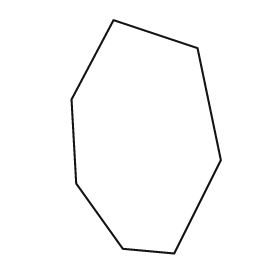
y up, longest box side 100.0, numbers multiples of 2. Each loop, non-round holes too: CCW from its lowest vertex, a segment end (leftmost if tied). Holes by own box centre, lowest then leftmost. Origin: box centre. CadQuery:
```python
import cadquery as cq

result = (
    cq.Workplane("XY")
    .moveTo(12.0, -50.0)
    .lineTo(32.0, -10.0)
    .lineTo(22.0, 38.0)
    .lineTo(-14.0, 50.0)
    .lineTo(-32.0, 16.0)
    .lineTo(-30.0, -20.0)
    .lineTo(-10.0, -48.0)
    .close()
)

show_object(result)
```